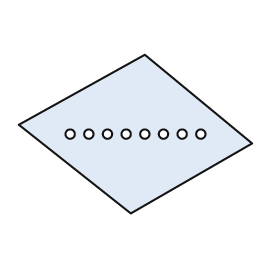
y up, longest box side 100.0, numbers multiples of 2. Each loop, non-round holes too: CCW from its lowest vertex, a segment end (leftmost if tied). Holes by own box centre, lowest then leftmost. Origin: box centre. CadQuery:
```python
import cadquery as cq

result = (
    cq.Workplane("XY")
    .moveTo(-2.0, -34.0)
    .lineTo(50.0, -4.0)
    .lineTo(4.0, 34.0)
    .lineTo(-50.0, 4.0)
    .close()
    .moveTo(-28.0, 0.0)
    .circle(2.0)
    .moveTo(-20.0, 0.0)
    .circle(2.0)
    .moveTo(-12.0, 0.0)
    .circle(2.0)
    .moveTo(-4.0, 0.0)
    .circle(2.0)
    .moveTo(4.0, 0.0)
    .circle(2.0)
    .moveTo(12.0, 0.0)
    .circle(2.0)
    .moveTo(20.0, 0.0)
    .circle(2.0)
    .moveTo(28.0, 0.0)
    .circle(2.0)
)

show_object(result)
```